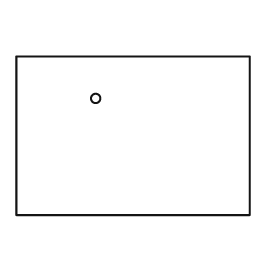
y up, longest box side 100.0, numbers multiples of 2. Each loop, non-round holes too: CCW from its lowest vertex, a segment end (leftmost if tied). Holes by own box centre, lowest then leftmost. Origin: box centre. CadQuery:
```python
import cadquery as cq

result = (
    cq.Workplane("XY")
    .moveTo(-50.0, -34.0)
    .lineTo(50.0, -34.0)
    .lineTo(50.0, 34.0)
    .lineTo(-50.0, 34.0)
    .close()
    .moveTo(-16.0, 16.0)
    .circle(2.0)
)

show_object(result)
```